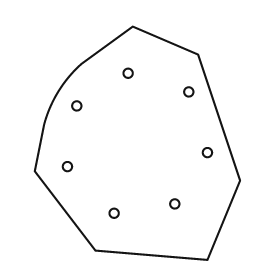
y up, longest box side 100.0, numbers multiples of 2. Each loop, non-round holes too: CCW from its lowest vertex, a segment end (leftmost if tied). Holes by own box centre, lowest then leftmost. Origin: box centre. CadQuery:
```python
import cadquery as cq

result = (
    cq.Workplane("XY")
    .moveTo(30.0, -50.0)
    .lineTo(44.0, -16.0)
    .lineTo(26.0, 38.0)
    .lineTo(-2.0, 50.0)
    .lineTo(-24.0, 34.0)
    .threePointArc((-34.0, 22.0), (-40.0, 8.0))
    .lineTo(-44.0, -12.0)
    .lineTo(-18.0, -46.0)
    .close()
    .moveTo(-10.0, -30.0)
    .circle(2.0)
    .moveTo(16.0, -26.0)
    .circle(2.0)
    .moveTo(-30.0, -10.0)
    .circle(2.0)
    .moveTo(30.0, -4.0)
    .circle(2.0)
    .moveTo(-26.0, 16.0)
    .circle(2.0)
    .moveTo(22.0, 22.0)
    .circle(2.0)
    .moveTo(-4.0, 30.0)
    .circle(2.0)
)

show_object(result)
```